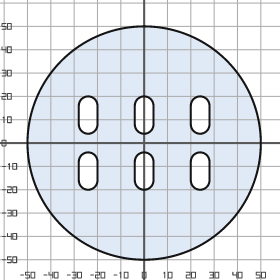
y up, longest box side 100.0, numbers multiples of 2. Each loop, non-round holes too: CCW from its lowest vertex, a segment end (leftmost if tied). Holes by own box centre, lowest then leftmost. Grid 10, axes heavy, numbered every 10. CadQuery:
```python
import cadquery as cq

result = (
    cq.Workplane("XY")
    .moveTo(0.0, 0.0)
    .circle(50.0)
    .moveTo(-28.0, -16.0)
    .threePointArc((-24.0, -20.0), (-20.0, -16.0))
    .lineTo(-20.0, -8.0)
    .threePointArc((-24.0, -4.0), (-28.0, -8.0))
    .close()
    .moveTo(-4.0, -16.0)
    .threePointArc((0.0, -20.0), (4.0, -16.0))
    .lineTo(4.0, -8.0)
    .threePointArc((0.0, -4.0), (-4.0, -8.0))
    .close()
    .moveTo(20.0, -16.0)
    .threePointArc((24.0, -20.0), (28.0, -16.0))
    .lineTo(28.0, -8.0)
    .threePointArc((24.0, -4.0), (20.0, -8.0))
    .close()
    .moveTo(-28.0, 8.0)
    .threePointArc((-24.0, 4.0), (-20.0, 8.0))
    .lineTo(-20.0, 16.0)
    .threePointArc((-24.0, 20.0), (-28.0, 16.0))
    .close()
    .moveTo(-4.0, 8.0)
    .threePointArc((0.0, 4.0), (4.0, 8.0))
    .lineTo(4.0, 16.0)
    .threePointArc((0.0, 20.0), (-4.0, 16.0))
    .close()
    .moveTo(20.0, 8.0)
    .threePointArc((24.0, 4.0), (28.0, 8.0))
    .lineTo(28.0, 16.0)
    .threePointArc((24.0, 20.0), (20.0, 16.0))
    .close()
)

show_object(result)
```